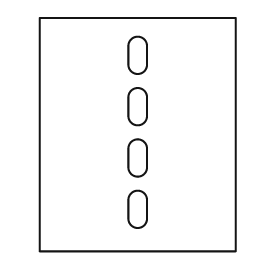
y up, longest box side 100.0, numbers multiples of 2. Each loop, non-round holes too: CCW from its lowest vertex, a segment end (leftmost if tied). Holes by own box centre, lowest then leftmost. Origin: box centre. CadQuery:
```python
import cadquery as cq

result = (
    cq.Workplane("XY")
    .moveTo(-42.0, -50.0)
    .lineTo(42.0, -50.0)
    .lineTo(42.0, 50.0)
    .lineTo(-42.0, 50.0)
    .close()
    .moveTo(-4.0, -36.0)
    .threePointArc((0.0, -40.0), (4.0, -36.0))
    .lineTo(4.0, -28.0)
    .threePointArc((0.0, -24.0), (-4.0, -28.0))
    .close()
    .moveTo(-4.0, -14.0)
    .threePointArc((0.0, -18.0), (4.0, -14.0))
    .lineTo(4.0, -6.0)
    .threePointArc((0.0, -2.0), (-4.0, -6.0))
    .close()
    .moveTo(-4.0, 8.0)
    .threePointArc((0.0, 4.0), (4.0, 8.0))
    .lineTo(4.0, 16.0)
    .threePointArc((0.0, 20.0), (-4.0, 16.0))
    .close()
    .moveTo(-4.0, 30.0)
    .threePointArc((0.0, 26.0), (4.0, 30.0))
    .lineTo(4.0, 38.0)
    .threePointArc((0.0, 42.0), (-4.0, 38.0))
    .close()
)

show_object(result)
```